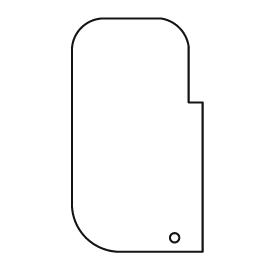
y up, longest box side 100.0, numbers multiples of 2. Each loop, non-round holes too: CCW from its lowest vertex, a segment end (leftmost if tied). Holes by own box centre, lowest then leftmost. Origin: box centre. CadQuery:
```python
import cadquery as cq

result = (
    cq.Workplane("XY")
    .moveTo(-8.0, -50.0)
    .lineTo(28.0, -50.0)
    .lineTo(28.0, 14.0)
    .lineTo(22.0, 14.0)
    .lineTo(22.0, 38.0)
    .threePointArc((18.0, 46.0), (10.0, 50.0))
    .lineTo(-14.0, 50.0)
    .threePointArc((-24.0, 46.0), (-28.0, 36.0))
    .lineTo(-28.0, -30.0)
    .threePointArc((-22.0, -44.0), (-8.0, -50.0))
    .close()
    .moveTo(16.0, -44.0)
    .circle(2.0)
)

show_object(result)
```